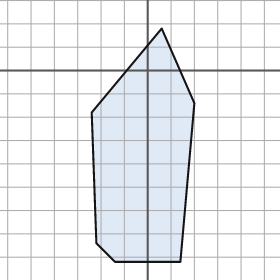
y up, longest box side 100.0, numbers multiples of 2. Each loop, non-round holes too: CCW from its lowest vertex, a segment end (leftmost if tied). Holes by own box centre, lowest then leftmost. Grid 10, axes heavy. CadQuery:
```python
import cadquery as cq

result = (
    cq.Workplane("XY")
    .moveTo(-14.0, -82.0)
    .lineTo(14.0, -82.0)
    .lineTo(20.0, -14.0)
    .lineTo(6.0, 18.0)
    .lineTo(-24.0, -18.0)
    .lineTo(-22.0, -74.0)
    .close()
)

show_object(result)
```